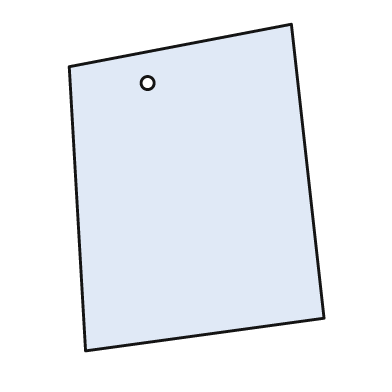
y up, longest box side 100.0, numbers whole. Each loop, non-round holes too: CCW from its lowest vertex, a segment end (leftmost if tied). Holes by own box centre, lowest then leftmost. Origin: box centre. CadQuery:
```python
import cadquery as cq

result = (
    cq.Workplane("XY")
    .moveTo(-34.0, -50.0)
    .lineTo(39.0, -40.0)
    .lineTo(29.0, 50.0)
    .lineTo(-39.0, 37.0)
    .close()
    .moveTo(-15.0, 32.0)
    .circle(2.0)
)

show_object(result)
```